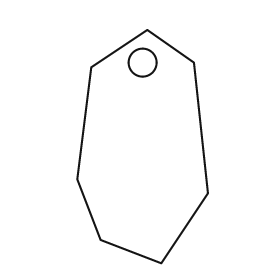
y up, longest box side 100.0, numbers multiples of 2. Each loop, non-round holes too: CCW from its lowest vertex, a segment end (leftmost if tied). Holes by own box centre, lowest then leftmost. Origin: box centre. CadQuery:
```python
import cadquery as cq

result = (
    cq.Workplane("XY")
    .moveTo(8.0, -50.0)
    .lineTo(28.0, -20.0)
    .lineTo(22.0, 36.0)
    .lineTo(2.0, 50.0)
    .lineTo(-22.0, 34.0)
    .lineTo(-28.0, -14.0)
    .lineTo(-18.0, -40.0)
    .close()
    .moveTo(0.0, 36.0)
    .circle(6.0)
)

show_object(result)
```